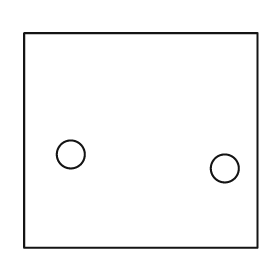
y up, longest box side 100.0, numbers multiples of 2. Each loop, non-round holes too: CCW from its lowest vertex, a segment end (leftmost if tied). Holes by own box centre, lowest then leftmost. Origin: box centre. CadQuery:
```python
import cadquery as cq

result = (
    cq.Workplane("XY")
    .moveTo(-50.0, -46.0)
    .lineTo(50.0, -46.0)
    .lineTo(50.0, 46.0)
    .lineTo(-50.0, 46.0)
    .close()
    .moveTo(36.0, -12.0)
    .circle(6.0)
    .moveTo(-30.0, -6.0)
    .circle(6.0)
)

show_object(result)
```